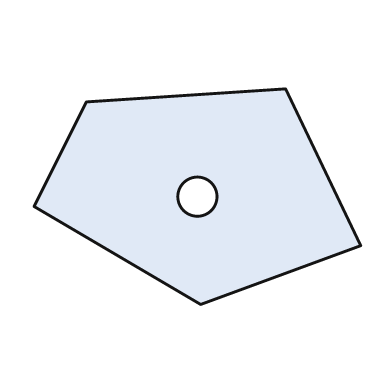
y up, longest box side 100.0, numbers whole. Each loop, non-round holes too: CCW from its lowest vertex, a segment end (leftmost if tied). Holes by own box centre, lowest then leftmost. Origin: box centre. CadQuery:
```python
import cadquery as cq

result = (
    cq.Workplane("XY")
    .moveTo(1.0, -33.0)
    .lineTo(50.0, -15.0)
    .lineTo(27.0, 33.0)
    .lineTo(-34.0, 29.0)
    .lineTo(-50.0, -3.0)
    .close()
    .moveTo(0.0, 0.0)
    .circle(6.0)
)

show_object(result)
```